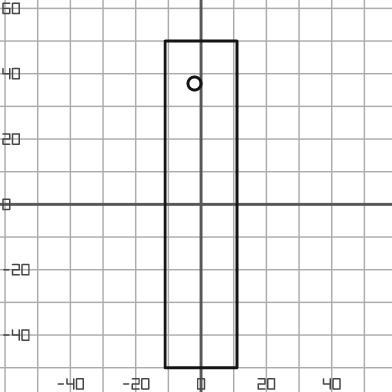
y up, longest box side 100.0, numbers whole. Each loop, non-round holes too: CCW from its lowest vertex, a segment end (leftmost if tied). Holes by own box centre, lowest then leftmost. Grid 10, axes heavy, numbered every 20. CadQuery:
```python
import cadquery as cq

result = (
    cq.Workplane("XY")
    .moveTo(-11.0, -50.0)
    .lineTo(11.0, -50.0)
    .lineTo(11.0, 50.0)
    .lineTo(-11.0, 50.0)
    .close()
    .moveTo(-2.0, 37.0)
    .circle(2.0)
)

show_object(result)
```